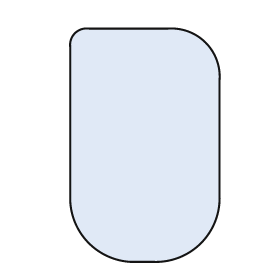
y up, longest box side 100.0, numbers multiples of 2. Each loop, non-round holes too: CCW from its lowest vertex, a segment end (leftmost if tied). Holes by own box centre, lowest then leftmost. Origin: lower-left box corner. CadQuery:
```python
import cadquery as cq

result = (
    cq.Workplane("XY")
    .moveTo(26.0, 0.0)
    .lineTo(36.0, 0.0)
    .threePointArc((56.0, 8.0), (64.0, 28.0))
    .lineTo(64.0, 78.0)
    .threePointArc((58.0, 94.0), (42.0, 100.0))
    .lineTo(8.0, 100.0)
    .threePointArc((2.0, 98.0), (0.0, 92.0))
    .lineTo(0.0, 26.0)
    .threePointArc((8.0, 8.0), (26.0, 0.0))
    .close()
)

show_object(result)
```